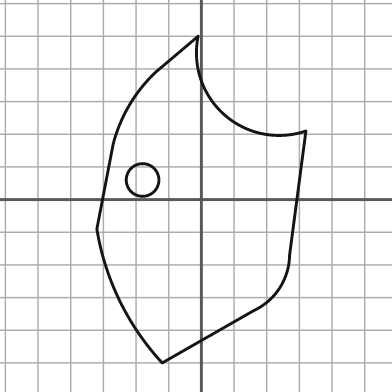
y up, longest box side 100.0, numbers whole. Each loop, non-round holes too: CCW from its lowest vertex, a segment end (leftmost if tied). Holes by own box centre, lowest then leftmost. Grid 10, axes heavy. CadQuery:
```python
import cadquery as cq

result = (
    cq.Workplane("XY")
    .moveTo(-12.0, -50.0)
    .lineTo(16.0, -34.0)
    .threePointArc((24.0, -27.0), (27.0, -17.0))
    .lineTo(32.0, 21.0)
    .threePointArc((7.0, 26.0), (-1.0, 50.0))
    .lineTo(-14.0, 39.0)
    .threePointArc((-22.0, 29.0), (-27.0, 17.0))
    .lineTo(-32.0, -9.0)
    .threePointArc((-25.0, -31.0), (-12.0, -50.0))
    .close()
    .moveTo(-18.0, 6.0)
    .circle(5.0)
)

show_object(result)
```